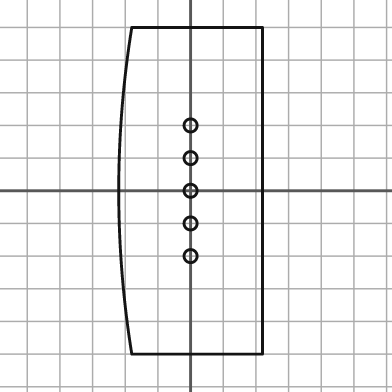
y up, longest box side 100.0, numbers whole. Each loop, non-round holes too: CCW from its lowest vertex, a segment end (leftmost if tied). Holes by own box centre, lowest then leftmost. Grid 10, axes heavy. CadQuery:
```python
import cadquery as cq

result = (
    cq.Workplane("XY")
    .moveTo(-18.0, -50.0)
    .lineTo(22.0, -50.0)
    .lineTo(22.0, 50.0)
    .lineTo(-18.0, 50.0)
    .threePointArc((-22.0, 0.0), (-18.0, -50.0))
    .close()
    .moveTo(0.0, -20.0)
    .circle(2.0)
    .moveTo(0.0, -10.0)
    .circle(2.0)
    .moveTo(0.0, 0.0)
    .circle(2.0)
    .moveTo(0.0, 10.0)
    .circle(2.0)
    .moveTo(0.0, 20.0)
    .circle(2.0)
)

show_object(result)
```